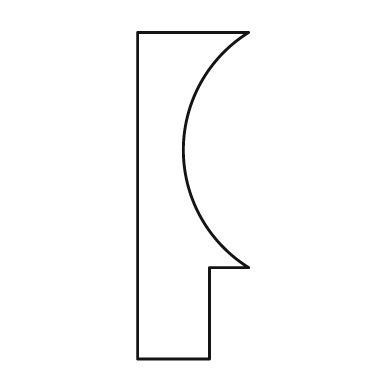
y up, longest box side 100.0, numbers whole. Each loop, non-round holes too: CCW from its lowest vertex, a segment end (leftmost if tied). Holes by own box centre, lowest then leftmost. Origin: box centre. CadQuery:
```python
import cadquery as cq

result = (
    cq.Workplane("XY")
    .moveTo(-17.0, -50.0)
    .lineTo(5.0, -50.0)
    .lineTo(5.0, -22.0)
    .lineTo(17.0, -22.0)
    .threePointArc((-3.0, 14.0), (17.0, 50.0))
    .lineTo(-17.0, 50.0)
    .close()
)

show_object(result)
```